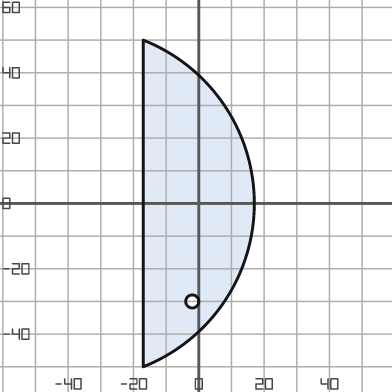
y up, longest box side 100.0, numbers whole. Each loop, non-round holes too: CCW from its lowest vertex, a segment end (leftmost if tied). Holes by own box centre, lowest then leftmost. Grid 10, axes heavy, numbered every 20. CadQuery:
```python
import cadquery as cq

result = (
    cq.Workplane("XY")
    .moveTo(-17.0, -50.0)
    .threePointArc((17.0, 0.0), (-17.0, 50.0))
    .close()
    .moveTo(-2.0, -30.0)
    .circle(2.0)
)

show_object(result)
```